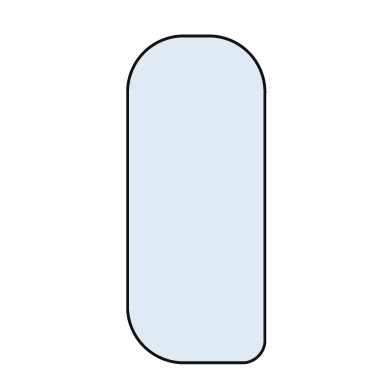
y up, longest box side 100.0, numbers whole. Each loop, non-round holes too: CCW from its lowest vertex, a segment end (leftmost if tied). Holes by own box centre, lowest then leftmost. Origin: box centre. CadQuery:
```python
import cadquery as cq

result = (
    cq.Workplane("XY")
    .moveTo(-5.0, -50.0)
    .lineTo(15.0, -50.0)
    .threePointArc((19.0, -48.0), (21.0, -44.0))
    .lineTo(21.0, 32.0)
    .threePointArc((16.0, 45.0), (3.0, 50.0))
    .lineTo(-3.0, 50.0)
    .threePointArc((-16.0, 45.0), (-21.0, 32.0))
    .lineTo(-21.0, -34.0)
    .threePointArc((-16.0, -45.0), (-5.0, -50.0))
    .close()
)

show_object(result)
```